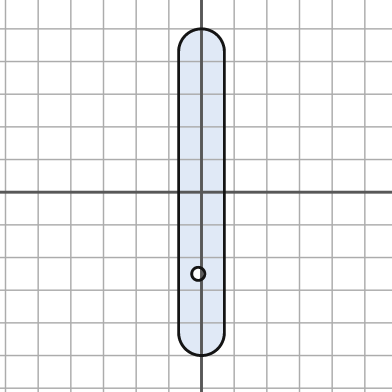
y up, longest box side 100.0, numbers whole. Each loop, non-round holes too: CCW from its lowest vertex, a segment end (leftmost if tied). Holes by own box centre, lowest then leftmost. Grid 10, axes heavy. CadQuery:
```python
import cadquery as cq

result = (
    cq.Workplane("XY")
    .moveTo(-7.0, -43.0)
    .threePointArc((0.0, -50.0), (7.0, -43.0))
    .lineTo(7.0, 43.0)
    .threePointArc((0.0, 50.0), (-7.0, 43.0))
    .close()
    .moveTo(-1.0, -25.0)
    .circle(2.0)
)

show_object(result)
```